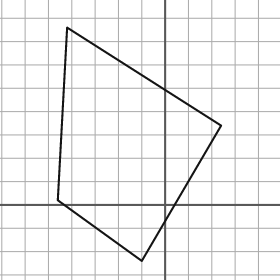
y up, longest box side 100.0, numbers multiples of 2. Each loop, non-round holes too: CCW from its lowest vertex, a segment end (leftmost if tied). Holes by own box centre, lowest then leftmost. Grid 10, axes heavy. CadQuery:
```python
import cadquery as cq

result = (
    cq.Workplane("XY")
    .moveTo(-10.0, -24.0)
    .lineTo(24.0, 34.0)
    .lineTo(-42.0, 76.0)
    .lineTo(-46.0, 2.0)
    .close()
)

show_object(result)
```